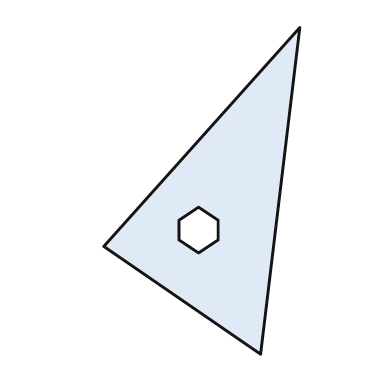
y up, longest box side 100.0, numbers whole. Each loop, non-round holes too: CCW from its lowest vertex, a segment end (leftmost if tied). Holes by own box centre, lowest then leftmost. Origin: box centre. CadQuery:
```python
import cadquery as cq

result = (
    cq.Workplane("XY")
    .moveTo(18.0, -50.0)
    .lineTo(30.0, 50.0)
    .lineTo(-30.0, -17.0)
    .close()
    .moveTo(-1.0, -19.0)
    .lineTo(5.0, -15.0)
    .lineTo(5.0, -9.0)
    .lineTo(-1.0, -5.0)
    .lineTo(-7.0, -9.0)
    .lineTo(-7.0, -15.0)
    .close()
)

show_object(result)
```